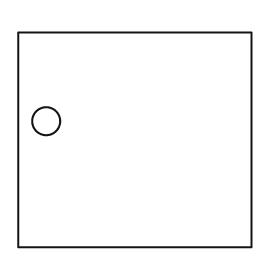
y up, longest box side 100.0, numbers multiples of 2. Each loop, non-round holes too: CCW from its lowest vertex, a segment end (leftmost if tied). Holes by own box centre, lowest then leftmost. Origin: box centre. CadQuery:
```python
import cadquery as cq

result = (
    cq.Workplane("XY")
    .moveTo(-50.0, -46.0)
    .lineTo(50.0, -46.0)
    .lineTo(50.0, 46.0)
    .lineTo(-50.0, 46.0)
    .close()
    .moveTo(-38.0, 8.0)
    .circle(6.0)
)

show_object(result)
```